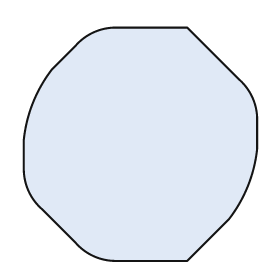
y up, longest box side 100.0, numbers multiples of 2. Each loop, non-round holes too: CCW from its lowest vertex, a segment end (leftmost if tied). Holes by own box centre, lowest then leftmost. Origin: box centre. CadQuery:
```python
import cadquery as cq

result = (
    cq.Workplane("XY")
    .moveTo(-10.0, -50.0)
    .lineTo(20.0, -50.0)
    .lineTo(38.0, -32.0)
    .threePointArc((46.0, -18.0), (50.0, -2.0))
    .lineTo(50.0, 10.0)
    .threePointArc((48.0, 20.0), (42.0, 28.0))
    .lineTo(20.0, 50.0)
    .lineTo(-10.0, 50.0)
    .threePointArc((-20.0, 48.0), (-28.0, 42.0))
    .lineTo(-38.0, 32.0)
    .threePointArc((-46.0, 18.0), (-50.0, 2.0))
    .lineTo(-50.0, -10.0)
    .threePointArc((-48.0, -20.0), (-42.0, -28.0))
    .lineTo(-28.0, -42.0)
    .threePointArc((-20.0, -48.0), (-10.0, -50.0))
    .close()
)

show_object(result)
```